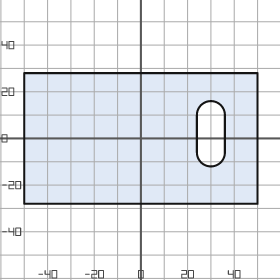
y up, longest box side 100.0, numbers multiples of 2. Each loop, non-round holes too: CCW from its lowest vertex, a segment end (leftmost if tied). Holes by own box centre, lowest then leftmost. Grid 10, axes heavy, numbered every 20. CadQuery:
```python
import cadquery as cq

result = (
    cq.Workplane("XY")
    .moveTo(-50.0, -28.0)
    .lineTo(50.0, -28.0)
    .lineTo(50.0, 28.0)
    .lineTo(-50.0, 28.0)
    .close()
    .moveTo(24.0, -6.0)
    .threePointArc((30.0, -12.0), (36.0, -6.0))
    .lineTo(36.0, 10.0)
    .threePointArc((30.0, 16.0), (24.0, 10.0))
    .close()
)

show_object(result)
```